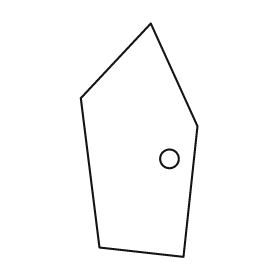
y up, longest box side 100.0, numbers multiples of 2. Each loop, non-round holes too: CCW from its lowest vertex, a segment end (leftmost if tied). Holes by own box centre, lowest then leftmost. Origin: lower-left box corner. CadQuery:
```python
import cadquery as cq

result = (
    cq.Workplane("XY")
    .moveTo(44.0, 0.0)
    .lineTo(50.0, 56.0)
    .lineTo(30.0, 100.0)
    .lineTo(0.0, 68.0)
    .lineTo(8.0, 4.0)
    .close()
    .moveTo(38.0, 42.0)
    .circle(4.0)
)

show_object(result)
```